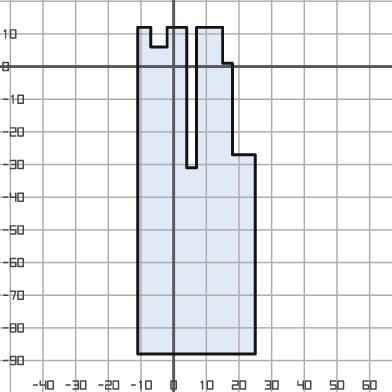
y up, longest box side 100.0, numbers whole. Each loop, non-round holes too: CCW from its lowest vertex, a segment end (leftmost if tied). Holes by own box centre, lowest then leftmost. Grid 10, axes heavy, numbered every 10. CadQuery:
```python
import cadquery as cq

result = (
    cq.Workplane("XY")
    .moveTo(-11.0, -88.0)
    .lineTo(25.0, -88.0)
    .lineTo(25.0, -27.0)
    .lineTo(18.0, -27.0)
    .lineTo(18.0, 1.0)
    .lineTo(15.0, 1.0)
    .lineTo(15.0, 12.0)
    .lineTo(7.0, 12.0)
    .lineTo(7.0, -31.0)
    .lineTo(4.0, -31.0)
    .lineTo(4.0, 12.0)
    .lineTo(-2.0, 12.0)
    .lineTo(-2.0, 6.0)
    .lineTo(-7.0, 6.0)
    .lineTo(-7.0, 12.0)
    .lineTo(-11.0, 12.0)
    .close()
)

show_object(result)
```